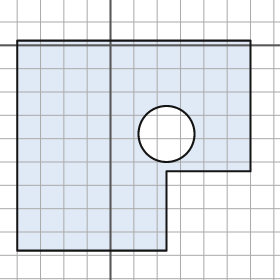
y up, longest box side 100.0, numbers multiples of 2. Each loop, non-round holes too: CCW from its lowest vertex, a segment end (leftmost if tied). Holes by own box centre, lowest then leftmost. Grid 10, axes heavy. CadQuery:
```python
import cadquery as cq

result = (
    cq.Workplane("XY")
    .moveTo(-40.0, -88.0)
    .lineTo(24.0, -88.0)
    .lineTo(24.0, -54.0)
    .lineTo(60.0, -54.0)
    .lineTo(60.0, 2.0)
    .lineTo(-40.0, 2.0)
    .close()
    .moveTo(24.0, -38.0)
    .circle(12.0)
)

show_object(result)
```